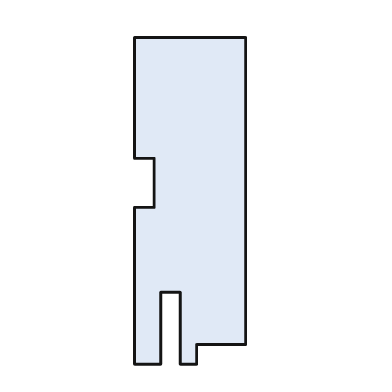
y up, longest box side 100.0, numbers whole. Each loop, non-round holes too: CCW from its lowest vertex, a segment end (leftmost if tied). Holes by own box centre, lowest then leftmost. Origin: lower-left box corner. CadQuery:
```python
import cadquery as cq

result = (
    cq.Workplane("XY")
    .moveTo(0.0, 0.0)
    .lineTo(8.0, 0.0)
    .lineTo(8.0, 22.0)
    .lineTo(14.0, 22.0)
    .lineTo(14.0, 0.0)
    .lineTo(19.0, 0.0)
    .lineTo(19.0, 6.0)
    .lineTo(34.0, 6.0)
    .lineTo(34.0, 100.0)
    .lineTo(0.0, 100.0)
    .lineTo(0.0, 63.0)
    .lineTo(6.0, 63.0)
    .lineTo(6.0, 48.0)
    .lineTo(0.0, 48.0)
    .close()
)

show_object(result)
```